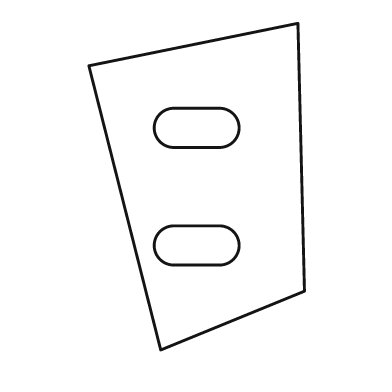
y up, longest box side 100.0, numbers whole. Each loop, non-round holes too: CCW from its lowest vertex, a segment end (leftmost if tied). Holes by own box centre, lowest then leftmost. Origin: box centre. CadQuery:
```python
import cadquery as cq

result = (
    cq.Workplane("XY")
    .moveTo(-11.0, -50.0)
    .lineTo(33.0, -32.0)
    .lineTo(31.0, 50.0)
    .lineTo(-33.0, 37.0)
    .close()
    .moveTo(-7.0, -24.0)
    .lineTo(7.0, -24.0)
    .threePointArc((13.0, -18.0), (7.0, -12.0))
    .lineTo(-7.0, -12.0)
    .threePointArc((-13.0, -18.0), (-7.0, -24.0))
    .close()
    .moveTo(-7.0, 12.0)
    .lineTo(7.0, 12.0)
    .threePointArc((13.0, 18.0), (7.0, 24.0))
    .lineTo(-7.0, 24.0)
    .threePointArc((-13.0, 18.0), (-7.0, 12.0))
    .close()
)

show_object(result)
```